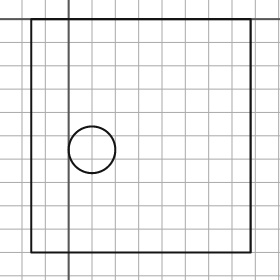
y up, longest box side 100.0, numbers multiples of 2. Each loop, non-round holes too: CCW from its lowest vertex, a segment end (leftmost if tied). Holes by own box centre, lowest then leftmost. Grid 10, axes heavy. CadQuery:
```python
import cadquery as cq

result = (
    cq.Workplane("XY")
    .moveTo(-16.0, -100.0)
    .lineTo(78.0, -100.0)
    .lineTo(78.0, 0.0)
    .lineTo(-16.0, 0.0)
    .close()
    .moveTo(10.0, -56.0)
    .circle(10.0)
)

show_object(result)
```